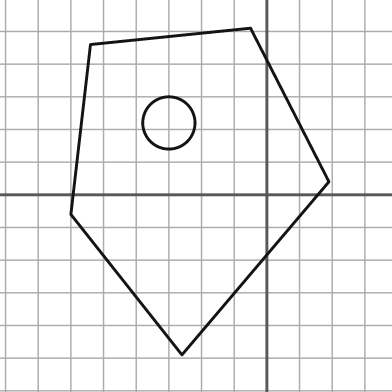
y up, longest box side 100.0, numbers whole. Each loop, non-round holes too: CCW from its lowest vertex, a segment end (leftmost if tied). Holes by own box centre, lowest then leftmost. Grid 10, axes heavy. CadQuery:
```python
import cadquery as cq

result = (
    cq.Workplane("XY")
    .moveTo(-26.0, -49.0)
    .lineTo(19.0, 4.0)
    .lineTo(-5.0, 51.0)
    .lineTo(-54.0, 46.0)
    .lineTo(-60.0, -6.0)
    .close()
    .moveTo(-30.0, 22.0)
    .circle(8.0)
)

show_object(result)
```